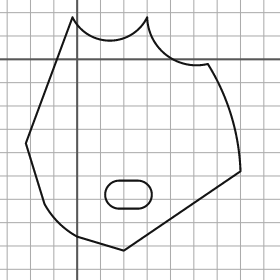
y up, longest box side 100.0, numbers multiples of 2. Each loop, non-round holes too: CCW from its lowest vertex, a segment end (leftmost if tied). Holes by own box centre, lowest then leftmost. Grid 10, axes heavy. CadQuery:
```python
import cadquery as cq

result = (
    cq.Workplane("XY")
    .moveTo(20.0, -82.0)
    .lineTo(70.0, -48.0)
    .threePointArc((66.0, -24.0), (56.0, -2.0))
    .threePointArc((38.0, 2.0), (30.0, 18.0))
    .threePointArc((14.0, 8.0), (-2.0, 18.0))
    .lineTo(-22.0, -36.0)
    .lineTo(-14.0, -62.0)
    .threePointArc((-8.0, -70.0), (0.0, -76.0))
    .close()
    .moveTo(18.0, -64.0)
    .lineTo(26.0, -64.0)
    .threePointArc((32.0, -58.0), (26.0, -52.0))
    .lineTo(18.0, -52.0)
    .threePointArc((12.0, -58.0), (18.0, -64.0))
    .close()
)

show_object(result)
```